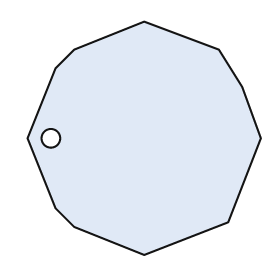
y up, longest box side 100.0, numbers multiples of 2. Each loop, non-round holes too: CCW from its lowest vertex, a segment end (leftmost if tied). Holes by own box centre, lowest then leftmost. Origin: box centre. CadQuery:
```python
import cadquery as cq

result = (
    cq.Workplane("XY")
    .moveTo(0.0, -50.0)
    .lineTo(36.0, -36.0)
    .lineTo(50.0, 0.0)
    .lineTo(42.0, 22.0)
    .lineTo(32.0, 38.0)
    .lineTo(0.0, 50.0)
    .lineTo(-30.0, 38.0)
    .lineTo(-38.0, 30.0)
    .lineTo(-50.0, 0.0)
    .lineTo(-38.0, -30.0)
    .lineTo(-30.0, -38.0)
    .close()
    .moveTo(-40.0, 0.0)
    .circle(4.0)
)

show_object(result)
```